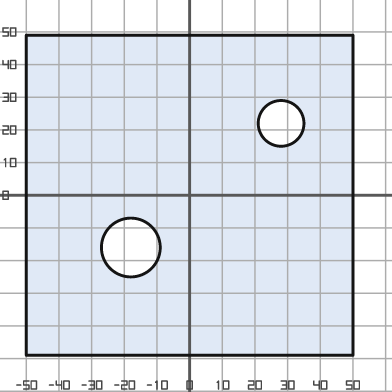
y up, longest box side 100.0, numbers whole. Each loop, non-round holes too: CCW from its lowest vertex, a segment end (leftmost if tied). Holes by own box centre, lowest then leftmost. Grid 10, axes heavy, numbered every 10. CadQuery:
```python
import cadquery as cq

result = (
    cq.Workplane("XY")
    .moveTo(-50.0, -49.0)
    .lineTo(50.0, -49.0)
    .lineTo(50.0, 49.0)
    .lineTo(-50.0, 49.0)
    .close()
    .moveTo(-18.0, -16.0)
    .circle(9.0)
    .moveTo(28.0, 22.0)
    .circle(7.0)
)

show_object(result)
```